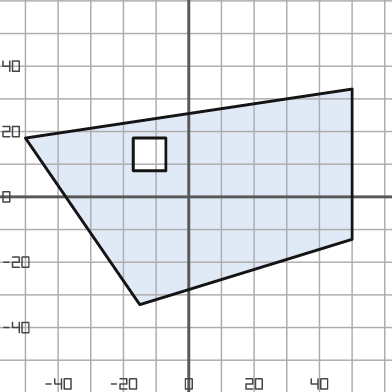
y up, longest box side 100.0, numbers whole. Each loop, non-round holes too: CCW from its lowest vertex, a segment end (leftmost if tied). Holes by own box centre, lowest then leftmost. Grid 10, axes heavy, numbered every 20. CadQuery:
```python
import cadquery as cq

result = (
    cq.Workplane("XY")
    .moveTo(-15.0, -33.0)
    .lineTo(50.0, -13.0)
    .lineTo(50.0, 33.0)
    .lineTo(-50.0, 18.0)
    .close()
    .moveTo(-17.0, 8.0)
    .lineTo(-7.0, 8.0)
    .lineTo(-7.0, 18.0)
    .lineTo(-17.0, 18.0)
    .close()
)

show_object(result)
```